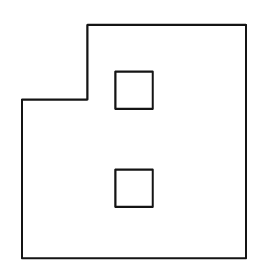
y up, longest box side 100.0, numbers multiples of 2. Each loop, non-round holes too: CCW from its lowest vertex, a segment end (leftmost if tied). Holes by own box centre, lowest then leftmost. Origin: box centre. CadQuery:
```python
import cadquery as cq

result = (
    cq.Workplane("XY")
    .moveTo(-48.0, -50.0)
    .lineTo(48.0, -50.0)
    .lineTo(48.0, 50.0)
    .lineTo(-20.0, 50.0)
    .lineTo(-20.0, 18.0)
    .lineTo(-48.0, 18.0)
    .close()
    .moveTo(-8.0, -28.0)
    .lineTo(8.0, -28.0)
    .lineTo(8.0, -12.0)
    .lineTo(-8.0, -12.0)
    .close()
    .moveTo(-8.0, 14.0)
    .lineTo(8.0, 14.0)
    .lineTo(8.0, 30.0)
    .lineTo(-8.0, 30.0)
    .close()
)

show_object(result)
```